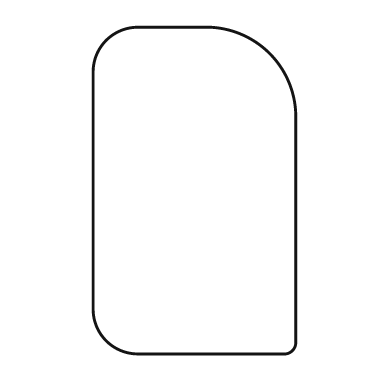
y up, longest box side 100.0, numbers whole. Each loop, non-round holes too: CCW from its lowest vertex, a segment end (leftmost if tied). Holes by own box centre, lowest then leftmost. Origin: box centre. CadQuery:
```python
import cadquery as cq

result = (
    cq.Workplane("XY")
    .moveTo(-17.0, -50.0)
    .lineTo(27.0, -50.0)
    .threePointArc((30.0, -49.0), (31.0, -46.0))
    .lineTo(31.0, 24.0)
    .threePointArc((23.0, 42.0), (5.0, 50.0))
    .lineTo(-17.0, 50.0)
    .threePointArc((-27.0, 46.0), (-31.0, 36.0))
    .lineTo(-31.0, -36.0)
    .threePointArc((-27.0, -46.0), (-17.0, -50.0))
    .close()
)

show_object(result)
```